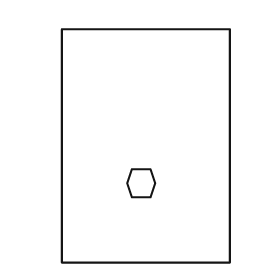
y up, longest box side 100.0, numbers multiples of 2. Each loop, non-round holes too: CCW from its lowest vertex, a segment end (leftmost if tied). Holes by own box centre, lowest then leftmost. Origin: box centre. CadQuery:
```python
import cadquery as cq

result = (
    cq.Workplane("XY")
    .moveTo(-36.0, -50.0)
    .lineTo(36.0, -50.0)
    .lineTo(36.0, 50.0)
    .lineTo(-36.0, 50.0)
    .close()
    .moveTo(-6.0, -22.0)
    .lineTo(2.0, -22.0)
    .lineTo(4.0, -16.0)
    .lineTo(2.0, -10.0)
    .lineTo(-6.0, -10.0)
    .lineTo(-8.0, -16.0)
    .close()
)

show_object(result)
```